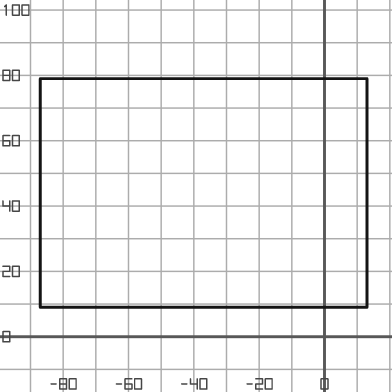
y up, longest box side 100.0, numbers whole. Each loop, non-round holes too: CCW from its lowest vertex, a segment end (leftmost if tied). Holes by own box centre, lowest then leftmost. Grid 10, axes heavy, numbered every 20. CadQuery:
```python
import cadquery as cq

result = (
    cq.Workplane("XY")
    .moveTo(-87.0, 9.0)
    .lineTo(13.0, 9.0)
    .lineTo(13.0, 79.0)
    .lineTo(-87.0, 79.0)
    .close()
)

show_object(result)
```